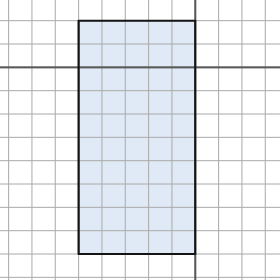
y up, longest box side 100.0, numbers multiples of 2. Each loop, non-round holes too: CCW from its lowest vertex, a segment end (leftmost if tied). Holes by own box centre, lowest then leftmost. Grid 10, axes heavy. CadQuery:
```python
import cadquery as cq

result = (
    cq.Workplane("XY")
    .moveTo(-50.0, -80.0)
    .lineTo(0.0, -80.0)
    .lineTo(0.0, 20.0)
    .lineTo(-50.0, 20.0)
    .close()
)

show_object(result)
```